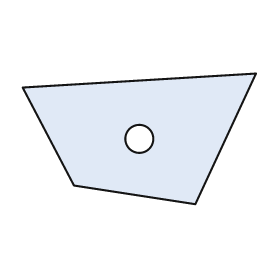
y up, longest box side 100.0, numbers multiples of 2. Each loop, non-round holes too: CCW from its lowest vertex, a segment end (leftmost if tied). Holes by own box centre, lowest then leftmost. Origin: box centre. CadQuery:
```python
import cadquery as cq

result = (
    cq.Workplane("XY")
    .moveTo(24.0, -28.0)
    .lineTo(50.0, 28.0)
    .lineTo(-50.0, 22.0)
    .lineTo(-28.0, -20.0)
    .close()
    .moveTo(0.0, 0.0)
    .circle(6.0)
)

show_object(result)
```